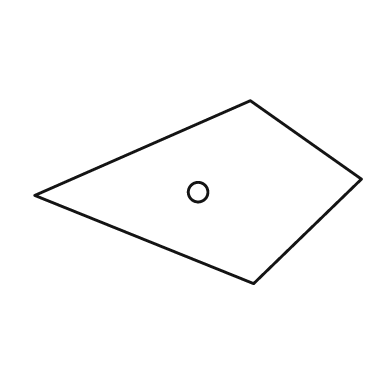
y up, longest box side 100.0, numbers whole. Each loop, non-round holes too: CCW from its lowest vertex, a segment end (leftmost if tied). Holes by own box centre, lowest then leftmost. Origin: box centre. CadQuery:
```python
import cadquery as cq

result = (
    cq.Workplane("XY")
    .moveTo(17.0, -28.0)
    .lineTo(50.0, 4.0)
    .lineTo(16.0, 28.0)
    .lineTo(-50.0, -1.0)
    .close()
    .moveTo(0.0, 0.0)
    .circle(3.0)
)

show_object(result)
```